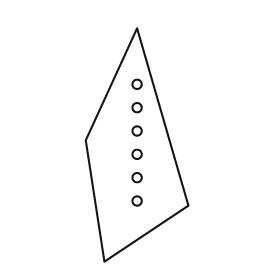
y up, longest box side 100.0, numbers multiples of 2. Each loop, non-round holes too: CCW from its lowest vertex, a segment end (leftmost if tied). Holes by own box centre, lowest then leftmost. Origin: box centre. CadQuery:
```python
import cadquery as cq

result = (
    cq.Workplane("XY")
    .moveTo(-14.0, -50.0)
    .lineTo(22.0, -26.0)
    .lineTo(0.0, 50.0)
    .lineTo(-22.0, 2.0)
    .close()
    .moveTo(0.0, -24.0)
    .circle(2.0)
    .moveTo(0.0, -14.0)
    .circle(2.0)
    .moveTo(0.0, -4.0)
    .circle(2.0)
    .moveTo(0.0, 6.0)
    .circle(2.0)
    .moveTo(0.0, 16.0)
    .circle(2.0)
    .moveTo(0.0, 26.0)
    .circle(2.0)
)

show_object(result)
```